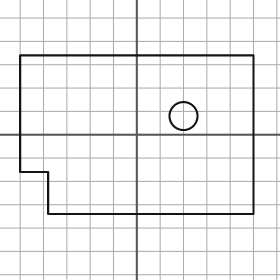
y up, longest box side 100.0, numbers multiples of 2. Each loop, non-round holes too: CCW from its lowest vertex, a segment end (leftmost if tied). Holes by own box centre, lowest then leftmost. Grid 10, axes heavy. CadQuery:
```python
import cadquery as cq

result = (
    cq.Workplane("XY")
    .moveTo(-38.0, -34.0)
    .lineTo(50.0, -34.0)
    .lineTo(50.0, 34.0)
    .lineTo(-50.0, 34.0)
    .lineTo(-50.0, -16.0)
    .lineTo(-38.0, -16.0)
    .close()
    .moveTo(20.0, 8.0)
    .circle(6.0)
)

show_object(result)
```